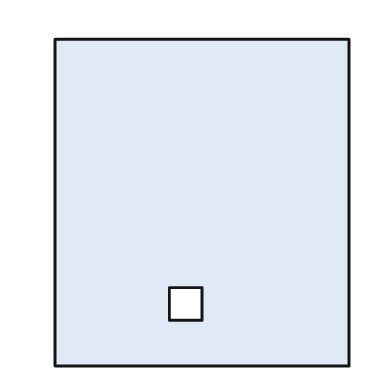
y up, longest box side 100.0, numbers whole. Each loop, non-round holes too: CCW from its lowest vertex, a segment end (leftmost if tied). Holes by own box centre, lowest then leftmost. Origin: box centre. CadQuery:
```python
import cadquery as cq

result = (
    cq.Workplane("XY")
    .moveTo(-45.0, -50.0)
    .lineTo(45.0, -50.0)
    .lineTo(45.0, 50.0)
    .lineTo(-45.0, 50.0)
    .close()
    .moveTo(-10.0, -36.0)
    .lineTo(0.0, -36.0)
    .lineTo(0.0, -26.0)
    .lineTo(-10.0, -26.0)
    .close()
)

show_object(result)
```